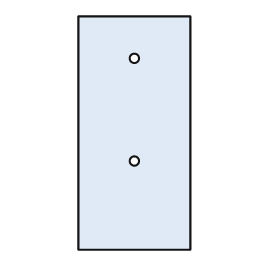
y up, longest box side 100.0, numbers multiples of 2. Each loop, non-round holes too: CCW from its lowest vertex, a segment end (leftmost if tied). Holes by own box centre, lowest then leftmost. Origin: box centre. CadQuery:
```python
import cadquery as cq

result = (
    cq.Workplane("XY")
    .moveTo(-24.0, -50.0)
    .lineTo(24.0, -50.0)
    .lineTo(24.0, 50.0)
    .lineTo(-24.0, 50.0)
    .close()
    .moveTo(0.0, -12.0)
    .circle(2.0)
    .moveTo(0.0, 32.0)
    .circle(2.0)
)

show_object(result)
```